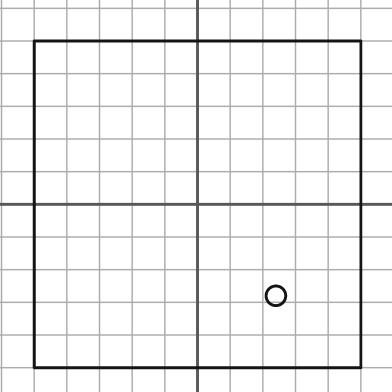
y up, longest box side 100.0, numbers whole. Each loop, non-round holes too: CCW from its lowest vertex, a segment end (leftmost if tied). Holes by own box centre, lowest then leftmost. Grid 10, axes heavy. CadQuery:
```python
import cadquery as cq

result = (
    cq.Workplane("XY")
    .moveTo(-50.0, -50.0)
    .lineTo(50.0, -50.0)
    .lineTo(50.0, 50.0)
    .lineTo(-50.0, 50.0)
    .close()
    .moveTo(24.0, -28.0)
    .circle(3.0)
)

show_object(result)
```